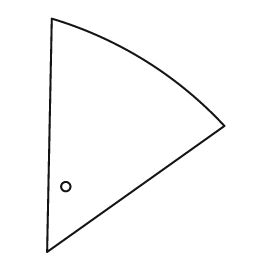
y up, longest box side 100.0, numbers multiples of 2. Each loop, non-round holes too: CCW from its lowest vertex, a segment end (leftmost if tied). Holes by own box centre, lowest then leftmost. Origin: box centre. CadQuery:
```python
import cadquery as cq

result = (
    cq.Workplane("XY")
    .moveTo(-38.0, -50.0)
    .lineTo(38.0, 4.0)
    .threePointArc((4.0, 32.0), (-36.0, 50.0))
    .close()
    .moveTo(-30.0, -22.0)
    .circle(2.0)
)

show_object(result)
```